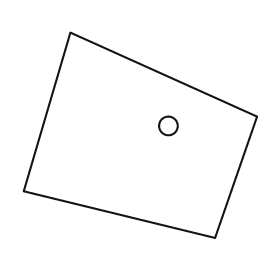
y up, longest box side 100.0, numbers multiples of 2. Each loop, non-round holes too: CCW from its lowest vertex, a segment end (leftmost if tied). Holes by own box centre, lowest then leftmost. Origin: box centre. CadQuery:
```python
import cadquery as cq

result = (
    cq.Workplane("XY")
    .moveTo(32.0, -44.0)
    .lineTo(50.0, 8.0)
    .lineTo(-30.0, 44.0)
    .lineTo(-50.0, -24.0)
    .close()
    .moveTo(12.0, 4.0)
    .circle(4.0)
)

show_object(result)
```